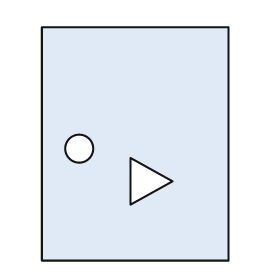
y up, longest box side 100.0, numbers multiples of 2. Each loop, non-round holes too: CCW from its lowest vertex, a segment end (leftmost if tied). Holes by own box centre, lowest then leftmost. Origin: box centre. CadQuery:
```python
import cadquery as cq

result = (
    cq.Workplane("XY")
    .moveTo(-40.0, -50.0)
    .lineTo(40.0, -50.0)
    .lineTo(40.0, 50.0)
    .lineTo(-40.0, 50.0)
    .close()
    .moveTo(-2.0, -26.0)
    .lineTo(16.0, -16.0)
    .lineTo(-2.0, -6.0)
    .close()
    .moveTo(-24.0, -2.0)
    .circle(6.0)
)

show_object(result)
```